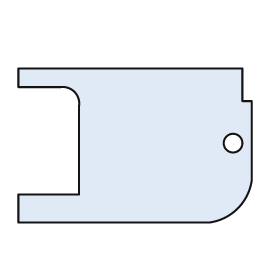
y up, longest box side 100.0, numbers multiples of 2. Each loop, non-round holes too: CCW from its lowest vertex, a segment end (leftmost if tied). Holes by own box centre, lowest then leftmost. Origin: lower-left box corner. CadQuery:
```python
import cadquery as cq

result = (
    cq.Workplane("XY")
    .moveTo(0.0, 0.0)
    .lineTo(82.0, 0.0)
    .threePointArc((94.0, 6.0), (100.0, 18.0))
    .lineTo(100.0, 52.0)
    .lineTo(96.0, 52.0)
    .lineTo(96.0, 66.0)
    .lineTo(0.0, 66.0)
    .lineTo(0.0, 58.0)
    .lineTo(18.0, 58.0)
    .threePointArc((24.0, 56.0), (26.0, 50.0))
    .lineTo(26.0, 12.0)
    .lineTo(0.0, 12.0)
    .close()
    .moveTo(92.0, 34.0)
    .circle(4.0)
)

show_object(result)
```